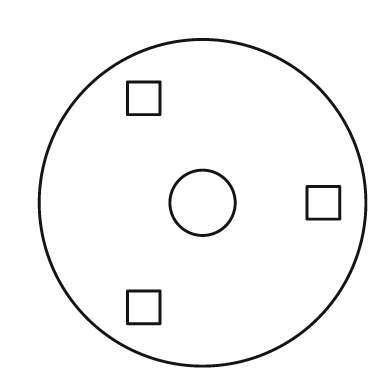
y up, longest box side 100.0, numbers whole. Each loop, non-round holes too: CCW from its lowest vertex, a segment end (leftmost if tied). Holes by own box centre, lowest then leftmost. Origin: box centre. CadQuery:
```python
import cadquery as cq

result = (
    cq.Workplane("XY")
    .moveTo(0.0, 0.0)
    .circle(50.0)
    .moveTo(-23.0, -37.0)
    .lineTo(-13.0, -37.0)
    .lineTo(-13.0, -27.0)
    .lineTo(-23.0, -27.0)
    .close()
    .moveTo(0.0, 0.0)
    .circle(10.0)
    .moveTo(32.0, -5.0)
    .lineTo(42.0, -5.0)
    .lineTo(42.0, 5.0)
    .lineTo(32.0, 5.0)
    .close()
    .moveTo(-23.0, 27.0)
    .lineTo(-13.0, 27.0)
    .lineTo(-13.0, 37.0)
    .lineTo(-23.0, 37.0)
    .close()
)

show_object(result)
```